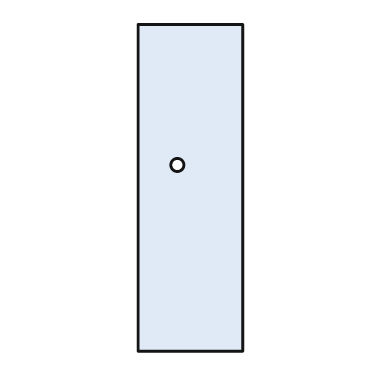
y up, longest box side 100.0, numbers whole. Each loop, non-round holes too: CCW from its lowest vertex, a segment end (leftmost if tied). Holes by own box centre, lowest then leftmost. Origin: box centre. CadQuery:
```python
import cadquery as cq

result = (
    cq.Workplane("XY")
    .moveTo(-16.0, -50.0)
    .lineTo(16.0, -50.0)
    .lineTo(16.0, 50.0)
    .lineTo(-16.0, 50.0)
    .close()
    .moveTo(-4.0, 7.0)
    .circle(2.0)
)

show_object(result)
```